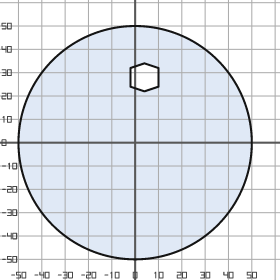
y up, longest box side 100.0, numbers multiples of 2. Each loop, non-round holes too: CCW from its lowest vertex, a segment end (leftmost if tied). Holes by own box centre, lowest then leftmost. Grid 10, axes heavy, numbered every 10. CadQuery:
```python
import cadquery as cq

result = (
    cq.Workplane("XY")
    .moveTo(0.0, 0.0)
    .circle(50.0)
    .moveTo(4.0, 22.0)
    .lineTo(10.0, 24.0)
    .lineTo(10.0, 32.0)
    .lineTo(4.0, 34.0)
    .lineTo(-2.0, 32.0)
    .lineTo(-2.0, 24.0)
    .close()
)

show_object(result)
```